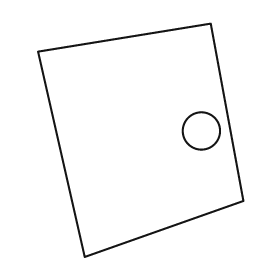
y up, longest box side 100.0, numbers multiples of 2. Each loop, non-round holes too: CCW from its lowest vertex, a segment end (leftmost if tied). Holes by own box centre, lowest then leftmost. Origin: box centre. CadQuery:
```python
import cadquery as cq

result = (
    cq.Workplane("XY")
    .moveTo(-24.0, -50.0)
    .lineTo(44.0, -26.0)
    .lineTo(30.0, 50.0)
    .lineTo(-44.0, 38.0)
    .close()
    .moveTo(26.0, 4.0)
    .circle(8.0)
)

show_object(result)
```